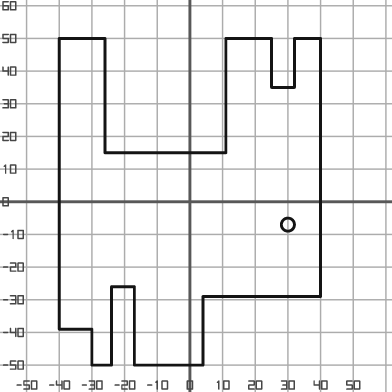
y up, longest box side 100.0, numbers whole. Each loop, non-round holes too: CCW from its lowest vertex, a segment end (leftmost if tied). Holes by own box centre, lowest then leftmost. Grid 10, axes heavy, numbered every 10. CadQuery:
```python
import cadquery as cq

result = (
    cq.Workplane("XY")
    .moveTo(-30.0, -50.0)
    .lineTo(-24.0, -50.0)
    .lineTo(-24.0, -26.0)
    .lineTo(-17.0, -26.0)
    .lineTo(-17.0, -50.0)
    .lineTo(4.0, -50.0)
    .lineTo(4.0, -29.0)
    .lineTo(40.0, -29.0)
    .lineTo(40.0, 50.0)
    .lineTo(32.0, 50.0)
    .lineTo(32.0, 35.0)
    .lineTo(25.0, 35.0)
    .lineTo(25.0, 50.0)
    .lineTo(11.0, 50.0)
    .lineTo(11.0, 15.0)
    .lineTo(-26.0, 15.0)
    .lineTo(-26.0, 50.0)
    .lineTo(-40.0, 50.0)
    .lineTo(-40.0, -39.0)
    .lineTo(-30.0, -39.0)
    .close()
    .moveTo(30.0, -7.0)
    .circle(2.0)
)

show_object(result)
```